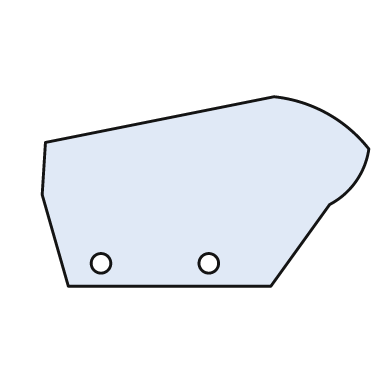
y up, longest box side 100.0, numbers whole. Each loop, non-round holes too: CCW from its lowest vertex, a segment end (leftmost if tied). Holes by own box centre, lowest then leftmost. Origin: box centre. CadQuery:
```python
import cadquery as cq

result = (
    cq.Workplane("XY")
    .moveTo(-42.0, -29.0)
    .lineTo(20.0, -29.0)
    .lineTo(38.0, -4.0)
    .threePointArc((46.0, 3.0), (50.0, 13.0))
    .threePointArc((37.0, 24.0), (21.0, 29.0))
    .lineTo(-49.0, 15.0)
    .lineTo(-50.0, -1.0)
    .close()
    .moveTo(-32.0, -22.0)
    .circle(3.0)
    .moveTo(1.0, -22.0)
    .circle(3.0)
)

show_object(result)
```